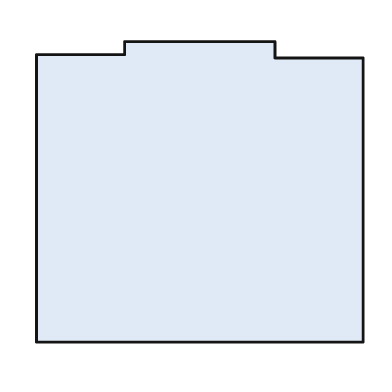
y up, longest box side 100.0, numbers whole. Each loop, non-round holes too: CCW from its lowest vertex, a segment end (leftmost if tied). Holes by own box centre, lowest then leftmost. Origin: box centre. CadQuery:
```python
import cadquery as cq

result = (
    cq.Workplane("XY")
    .moveTo(-50.0, -46.0)
    .lineTo(50.0, -46.0)
    .lineTo(50.0, 41.0)
    .lineTo(23.0, 41.0)
    .lineTo(23.0, 46.0)
    .lineTo(-23.0, 46.0)
    .lineTo(-23.0, 42.0)
    .lineTo(-50.0, 42.0)
    .close()
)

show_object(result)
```